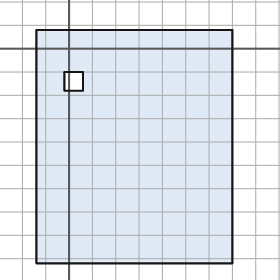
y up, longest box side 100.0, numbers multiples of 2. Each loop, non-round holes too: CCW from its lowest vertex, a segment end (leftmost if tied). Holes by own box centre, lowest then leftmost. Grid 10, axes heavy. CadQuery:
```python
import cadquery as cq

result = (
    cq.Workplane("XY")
    .moveTo(-14.0, -92.0)
    .lineTo(70.0, -92.0)
    .lineTo(70.0, 8.0)
    .lineTo(-14.0, 8.0)
    .close()
    .moveTo(-2.0, -18.0)
    .lineTo(6.0, -18.0)
    .lineTo(6.0, -10.0)
    .lineTo(-2.0, -10.0)
    .close()
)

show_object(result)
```